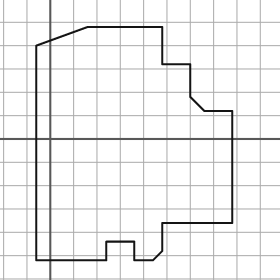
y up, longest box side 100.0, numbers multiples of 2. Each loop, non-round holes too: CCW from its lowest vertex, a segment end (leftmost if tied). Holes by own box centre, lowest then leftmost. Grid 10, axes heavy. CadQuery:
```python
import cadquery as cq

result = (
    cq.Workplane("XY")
    .moveTo(-6.0, -52.0)
    .lineTo(24.0, -52.0)
    .lineTo(24.0, -44.0)
    .lineTo(36.0, -44.0)
    .lineTo(36.0, -52.0)
    .lineTo(44.0, -52.0)
    .lineTo(48.0, -48.0)
    .lineTo(48.0, -36.0)
    .lineTo(78.0, -36.0)
    .lineTo(78.0, 12.0)
    .lineTo(66.0, 12.0)
    .lineTo(60.0, 18.0)
    .lineTo(60.0, 32.0)
    .lineTo(48.0, 32.0)
    .lineTo(48.0, 48.0)
    .lineTo(16.0, 48.0)
    .lineTo(-6.0, 40.0)
    .close()
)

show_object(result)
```